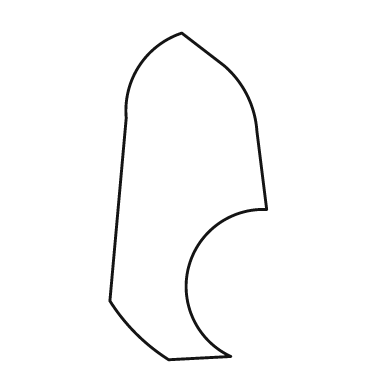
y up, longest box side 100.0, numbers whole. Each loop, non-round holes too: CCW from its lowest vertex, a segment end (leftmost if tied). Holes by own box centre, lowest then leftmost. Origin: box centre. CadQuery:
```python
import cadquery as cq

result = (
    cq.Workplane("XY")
    .moveTo(-6.0, -50.0)
    .lineTo(13.0, -49.0)
    .threePointArc((0.0, -22.0), (24.0, -4.0))
    .lineTo(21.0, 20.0)
    .threePointArc((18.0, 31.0), (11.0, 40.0))
    .lineTo(-2.0, 50.0)
    .threePointArc((-15.0, 40.0), (-19.0, 24.0))
    .lineTo(-24.0, -32.0)
    .threePointArc((-16.0, -42.0), (-6.0, -50.0))
    .close()
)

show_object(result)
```